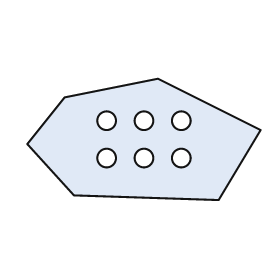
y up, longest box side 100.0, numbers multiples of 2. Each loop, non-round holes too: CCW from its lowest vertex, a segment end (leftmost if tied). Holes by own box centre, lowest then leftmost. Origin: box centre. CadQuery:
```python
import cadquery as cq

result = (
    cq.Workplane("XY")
    .moveTo(32.0, -26.0)
    .lineTo(50.0, 4.0)
    .lineTo(6.0, 26.0)
    .lineTo(-34.0, 18.0)
    .lineTo(-50.0, -2.0)
    .lineTo(-30.0, -24.0)
    .close()
    .moveTo(-16.0, -8.0)
    .circle(4.0)
    .moveTo(0.0, -8.0)
    .circle(4.0)
    .moveTo(16.0, -8.0)
    .circle(4.0)
    .moveTo(-16.0, 8.0)
    .circle(4.0)
    .moveTo(0.0, 8.0)
    .circle(4.0)
    .moveTo(16.0, 8.0)
    .circle(4.0)
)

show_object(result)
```